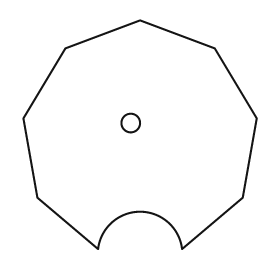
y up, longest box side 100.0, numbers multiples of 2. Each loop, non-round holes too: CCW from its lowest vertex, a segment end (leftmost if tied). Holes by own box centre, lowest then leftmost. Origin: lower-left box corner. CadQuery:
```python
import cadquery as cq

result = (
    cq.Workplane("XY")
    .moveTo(32.0, 0.0)
    .threePointArc((50.0, 16.0), (68.0, 0.0))
    .lineTo(94.0, 22.0)
    .lineTo(100.0, 56.0)
    .lineTo(82.0, 86.0)
    .lineTo(50.0, 98.0)
    .lineTo(18.0, 86.0)
    .lineTo(0.0, 56.0)
    .lineTo(6.0, 22.0)
    .close()
    .moveTo(46.0, 54.0)
    .circle(4.0)
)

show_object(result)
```